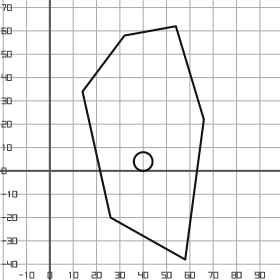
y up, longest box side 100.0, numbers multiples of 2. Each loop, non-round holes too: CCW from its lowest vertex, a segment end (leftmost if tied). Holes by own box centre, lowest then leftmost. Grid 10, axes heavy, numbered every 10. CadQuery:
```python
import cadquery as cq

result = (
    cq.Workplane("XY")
    .moveTo(58.0, -38.0)
    .lineTo(66.0, 22.0)
    .lineTo(54.0, 62.0)
    .lineTo(32.0, 58.0)
    .lineTo(14.0, 34.0)
    .lineTo(26.0, -20.0)
    .close()
    .moveTo(40.0, 4.0)
    .circle(4.0)
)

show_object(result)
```